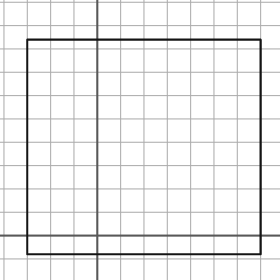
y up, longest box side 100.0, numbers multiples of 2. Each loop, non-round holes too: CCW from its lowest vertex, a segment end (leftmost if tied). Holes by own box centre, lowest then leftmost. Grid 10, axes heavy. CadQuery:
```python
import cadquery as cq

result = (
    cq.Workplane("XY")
    .moveTo(-30.0, -8.0)
    .lineTo(70.0, -8.0)
    .lineTo(70.0, 84.0)
    .lineTo(-30.0, 84.0)
    .close()
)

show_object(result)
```